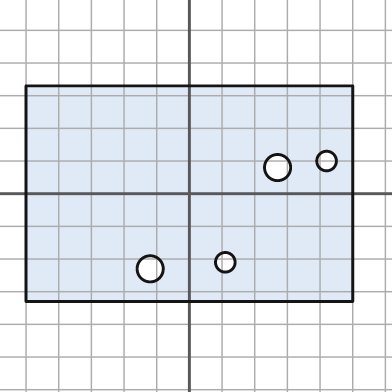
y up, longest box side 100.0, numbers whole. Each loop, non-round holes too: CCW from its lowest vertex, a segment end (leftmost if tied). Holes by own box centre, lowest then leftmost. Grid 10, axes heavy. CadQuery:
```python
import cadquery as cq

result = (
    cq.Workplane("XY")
    .moveTo(-50.0, -33.0)
    .lineTo(50.0, -33.0)
    .lineTo(50.0, 33.0)
    .lineTo(-50.0, 33.0)
    .close()
    .moveTo(-12.0, -23.0)
    .circle(4.0)
    .moveTo(11.0, -21.0)
    .circle(3.0)
    .moveTo(27.0, 8.0)
    .circle(4.0)
    .moveTo(42.0, 10.0)
    .circle(3.0)
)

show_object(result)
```